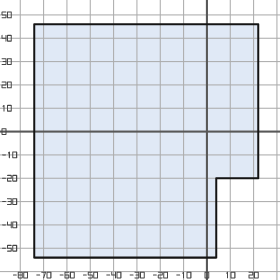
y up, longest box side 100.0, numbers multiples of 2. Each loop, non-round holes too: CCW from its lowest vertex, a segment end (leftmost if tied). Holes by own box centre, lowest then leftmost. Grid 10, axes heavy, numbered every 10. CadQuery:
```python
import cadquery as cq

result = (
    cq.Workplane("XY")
    .moveTo(-74.0, -54.0)
    .lineTo(4.0, -54.0)
    .lineTo(4.0, -20.0)
    .lineTo(22.0, -20.0)
    .lineTo(22.0, 46.0)
    .lineTo(-74.0, 46.0)
    .close()
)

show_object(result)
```